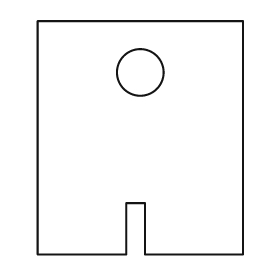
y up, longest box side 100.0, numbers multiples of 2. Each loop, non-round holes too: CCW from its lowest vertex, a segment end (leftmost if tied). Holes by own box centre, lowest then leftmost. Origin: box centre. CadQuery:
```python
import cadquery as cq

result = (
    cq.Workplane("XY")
    .moveTo(-44.0, -50.0)
    .lineTo(-6.0, -50.0)
    .lineTo(-6.0, -28.0)
    .lineTo(2.0, -28.0)
    .lineTo(2.0, -50.0)
    .lineTo(44.0, -50.0)
    .lineTo(44.0, 50.0)
    .lineTo(-44.0, 50.0)
    .close()
    .moveTo(0.0, 28.0)
    .circle(10.0)
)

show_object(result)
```